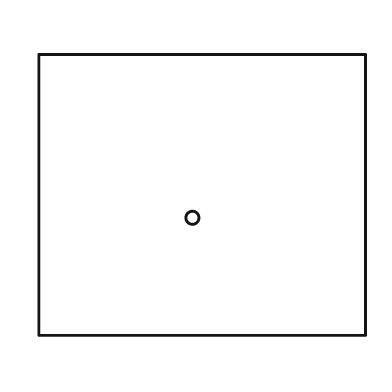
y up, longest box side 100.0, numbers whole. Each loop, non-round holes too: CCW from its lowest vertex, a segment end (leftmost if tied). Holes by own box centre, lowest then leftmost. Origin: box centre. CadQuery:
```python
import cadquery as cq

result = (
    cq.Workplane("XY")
    .moveTo(-50.0, -43.0)
    .lineTo(50.0, -43.0)
    .lineTo(50.0, 43.0)
    .lineTo(-50.0, 43.0)
    .close()
    .moveTo(-3.0, -7.0)
    .circle(2.0)
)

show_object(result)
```